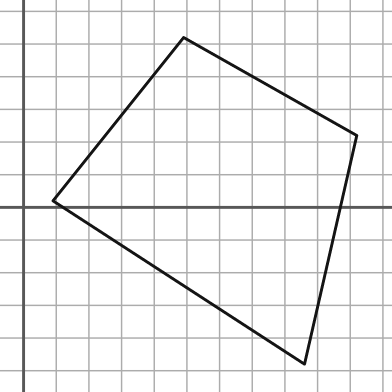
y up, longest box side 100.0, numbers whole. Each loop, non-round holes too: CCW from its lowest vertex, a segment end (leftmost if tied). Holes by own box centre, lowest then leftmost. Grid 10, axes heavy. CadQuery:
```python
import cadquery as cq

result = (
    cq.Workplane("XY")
    .moveTo(86.0, -48.0)
    .lineTo(102.0, 22.0)
    .lineTo(49.0, 52.0)
    .lineTo(9.0, 2.0)
    .close()
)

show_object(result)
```